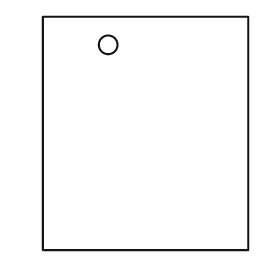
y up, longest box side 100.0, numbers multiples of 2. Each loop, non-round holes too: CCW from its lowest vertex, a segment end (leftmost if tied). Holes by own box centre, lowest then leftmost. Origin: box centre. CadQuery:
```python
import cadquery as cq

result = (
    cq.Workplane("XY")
    .moveTo(-44.0, -50.0)
    .lineTo(44.0, -50.0)
    .lineTo(44.0, 50.0)
    .lineTo(-44.0, 50.0)
    .close()
    .moveTo(-16.0, 38.0)
    .circle(4.0)
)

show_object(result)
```